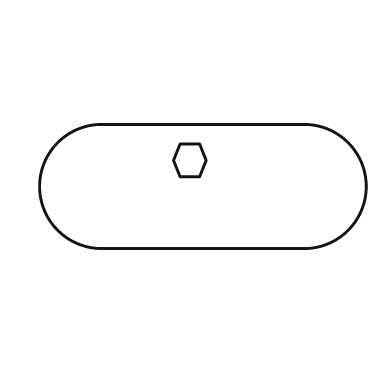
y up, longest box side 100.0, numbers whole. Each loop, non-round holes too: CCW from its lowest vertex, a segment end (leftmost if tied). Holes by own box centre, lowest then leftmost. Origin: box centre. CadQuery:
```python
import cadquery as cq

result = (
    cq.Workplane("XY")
    .moveTo(-31.0, -19.0)
    .lineTo(31.0, -19.0)
    .threePointArc((50.0, 0.0), (31.0, 19.0))
    .lineTo(-31.0, 19.0)
    .threePointArc((-50.0, 0.0), (-31.0, -19.0))
    .close()
    .moveTo(-7.0, 3.0)
    .lineTo(-1.0, 3.0)
    .lineTo(1.0, 8.0)
    .lineTo(-1.0, 13.0)
    .lineTo(-7.0, 13.0)
    .lineTo(-9.0, 8.0)
    .close()
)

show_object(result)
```